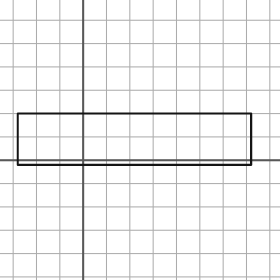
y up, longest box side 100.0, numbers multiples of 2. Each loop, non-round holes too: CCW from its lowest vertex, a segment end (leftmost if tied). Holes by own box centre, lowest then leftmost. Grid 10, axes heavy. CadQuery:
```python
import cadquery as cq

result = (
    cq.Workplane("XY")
    .moveTo(-28.0, -2.0)
    .lineTo(72.0, -2.0)
    .lineTo(72.0, 20.0)
    .lineTo(-28.0, 20.0)
    .close()
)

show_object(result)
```